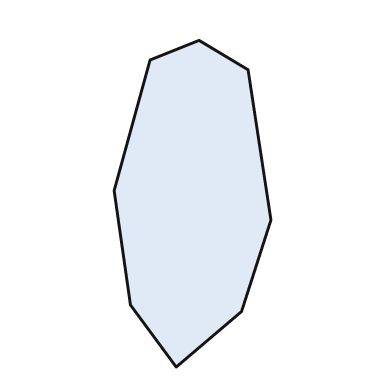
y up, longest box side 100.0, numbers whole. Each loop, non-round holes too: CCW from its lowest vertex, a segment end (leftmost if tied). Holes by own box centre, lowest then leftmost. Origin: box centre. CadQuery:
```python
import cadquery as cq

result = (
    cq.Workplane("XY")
    .moveTo(-5.0, -50.0)
    .lineTo(15.0, -33.0)
    .lineTo(24.0, -5.0)
    .lineTo(17.0, 41.0)
    .lineTo(2.0, 50.0)
    .lineTo(-13.0, 44.0)
    .lineTo(-24.0, 4.0)
    .lineTo(-19.0, -31.0)
    .close()
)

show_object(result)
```